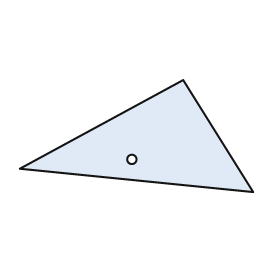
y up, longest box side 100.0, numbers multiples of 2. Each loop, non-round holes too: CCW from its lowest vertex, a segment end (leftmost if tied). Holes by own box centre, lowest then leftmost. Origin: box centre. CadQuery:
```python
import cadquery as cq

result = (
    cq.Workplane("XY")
    .moveTo(50.0, -24.0)
    .lineTo(20.0, 24.0)
    .lineTo(-50.0, -14.0)
    .close()
    .moveTo(-2.0, -10.0)
    .circle(2.0)
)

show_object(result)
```